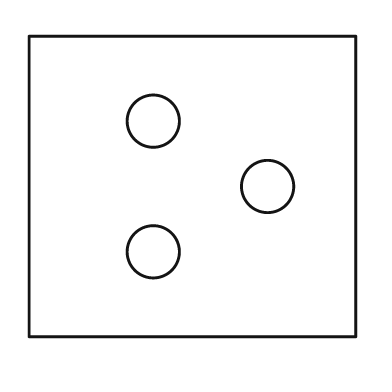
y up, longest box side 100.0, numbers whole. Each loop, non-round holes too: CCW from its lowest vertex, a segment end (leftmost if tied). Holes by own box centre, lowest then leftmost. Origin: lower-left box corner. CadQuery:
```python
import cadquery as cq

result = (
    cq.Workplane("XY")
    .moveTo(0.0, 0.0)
    .lineTo(100.0, 0.0)
    .lineTo(100.0, 92.0)
    .lineTo(0.0, 92.0)
    .close()
    .moveTo(38.0, 26.0)
    .circle(8.0)
    .moveTo(73.0, 46.0)
    .circle(8.0)
    .moveTo(38.0, 66.0)
    .circle(8.0)
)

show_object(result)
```